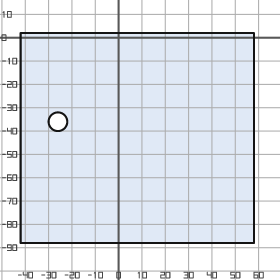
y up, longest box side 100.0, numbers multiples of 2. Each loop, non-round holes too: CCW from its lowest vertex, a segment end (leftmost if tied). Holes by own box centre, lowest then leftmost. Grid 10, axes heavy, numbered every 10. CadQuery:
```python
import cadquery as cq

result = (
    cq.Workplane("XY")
    .moveTo(-42.0, -88.0)
    .lineTo(58.0, -88.0)
    .lineTo(58.0, 2.0)
    .lineTo(-42.0, 2.0)
    .close()
    .moveTo(-26.0, -36.0)
    .circle(4.0)
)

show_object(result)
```